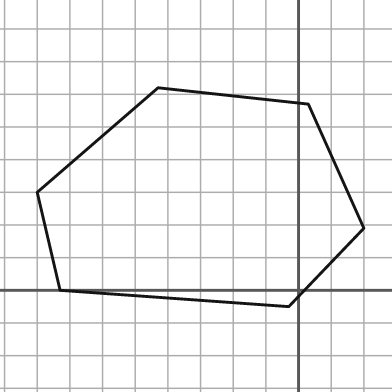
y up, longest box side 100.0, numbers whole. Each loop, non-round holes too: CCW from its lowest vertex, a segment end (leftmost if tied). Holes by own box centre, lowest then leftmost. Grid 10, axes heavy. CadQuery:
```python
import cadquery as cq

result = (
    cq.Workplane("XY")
    .moveTo(-3.0, -5.0)
    .lineTo(20.0, 19.0)
    .lineTo(3.0, 57.0)
    .lineTo(-43.0, 62.0)
    .lineTo(-80.0, 30.0)
    .lineTo(-73.0, 0.0)
    .close()
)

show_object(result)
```